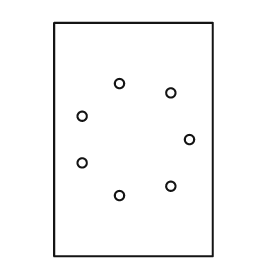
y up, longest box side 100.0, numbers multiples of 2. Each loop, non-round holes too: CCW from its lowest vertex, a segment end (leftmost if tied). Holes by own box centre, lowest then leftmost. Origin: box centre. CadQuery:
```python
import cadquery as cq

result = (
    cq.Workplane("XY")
    .moveTo(-34.0, -50.0)
    .lineTo(34.0, -50.0)
    .lineTo(34.0, 50.0)
    .lineTo(-34.0, 50.0)
    .close()
    .moveTo(-6.0, -24.0)
    .circle(2.0)
    .moveTo(16.0, -20.0)
    .circle(2.0)
    .moveTo(-22.0, -10.0)
    .circle(2.0)
    .moveTo(24.0, 0.0)
    .circle(2.0)
    .moveTo(-22.0, 10.0)
    .circle(2.0)
    .moveTo(16.0, 20.0)
    .circle(2.0)
    .moveTo(-6.0, 24.0)
    .circle(2.0)
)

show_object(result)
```